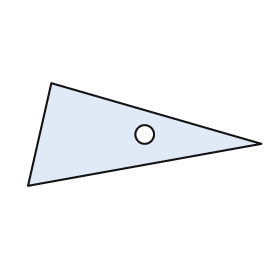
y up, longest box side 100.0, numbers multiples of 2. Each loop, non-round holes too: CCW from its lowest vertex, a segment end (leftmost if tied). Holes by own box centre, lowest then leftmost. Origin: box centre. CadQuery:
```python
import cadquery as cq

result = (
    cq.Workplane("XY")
    .moveTo(-50.0, -22.0)
    .lineTo(50.0, -4.0)
    .lineTo(-40.0, 22.0)
    .close()
    .moveTo(0.0, 0.0)
    .circle(4.0)
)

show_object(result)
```